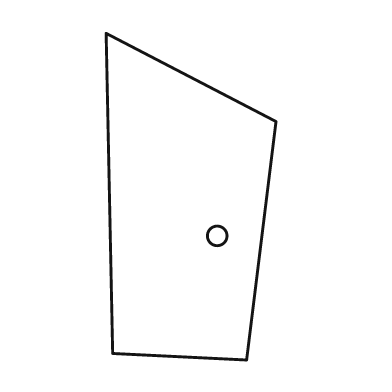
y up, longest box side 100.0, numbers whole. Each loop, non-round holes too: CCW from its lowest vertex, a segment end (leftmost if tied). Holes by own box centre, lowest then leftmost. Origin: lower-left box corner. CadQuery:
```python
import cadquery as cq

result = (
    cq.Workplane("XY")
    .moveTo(43.0, 0.0)
    .lineTo(52.0, 73.0)
    .lineTo(0.0, 100.0)
    .lineTo(2.0, 2.0)
    .close()
    .moveTo(34.0, 38.0)
    .circle(3.0)
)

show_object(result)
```